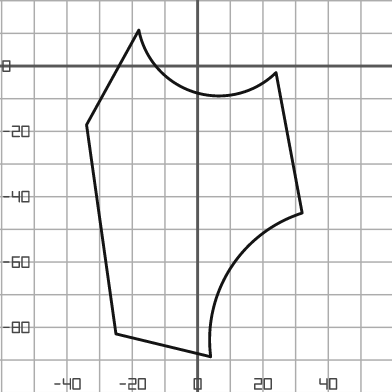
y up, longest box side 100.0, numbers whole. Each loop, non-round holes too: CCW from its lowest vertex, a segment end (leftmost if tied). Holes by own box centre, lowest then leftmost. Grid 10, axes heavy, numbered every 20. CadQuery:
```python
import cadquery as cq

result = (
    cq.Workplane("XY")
    .moveTo(4.0, -89.0)
    .threePointArc((10.0, -62.0), (32.0, -45.0))
    .lineTo(24.0, -2.0)
    .threePointArc((-1.0, -8.0), (-18.0, 11.0))
    .lineTo(-34.0, -18.0)
    .lineTo(-25.0, -82.0)
    .close()
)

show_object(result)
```